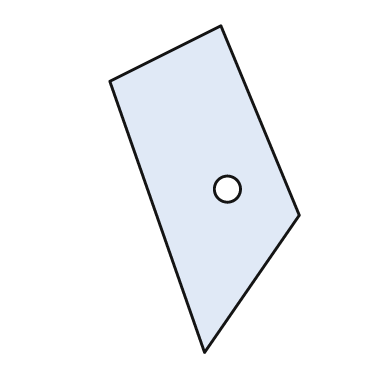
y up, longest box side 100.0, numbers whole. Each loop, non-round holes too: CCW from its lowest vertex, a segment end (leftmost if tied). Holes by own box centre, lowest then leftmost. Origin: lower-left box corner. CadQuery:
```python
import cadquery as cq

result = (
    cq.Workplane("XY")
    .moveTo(29.0, 0.0)
    .lineTo(58.0, 42.0)
    .lineTo(34.0, 100.0)
    .lineTo(0.0, 83.0)
    .close()
    .moveTo(36.0, 50.0)
    .circle(4.0)
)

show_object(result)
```